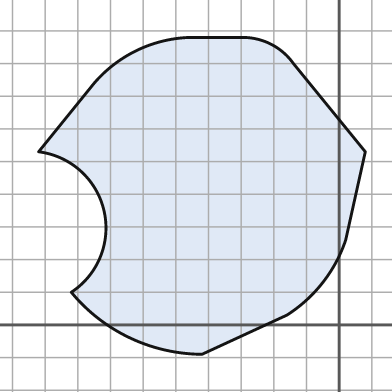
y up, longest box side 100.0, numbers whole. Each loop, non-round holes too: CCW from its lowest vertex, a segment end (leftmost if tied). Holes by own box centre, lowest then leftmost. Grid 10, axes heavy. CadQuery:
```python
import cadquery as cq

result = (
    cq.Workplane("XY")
    .moveTo(-42.0, -9.0)
    .lineTo(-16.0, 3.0)
    .threePointArc((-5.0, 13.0), (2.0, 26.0))
    .lineTo(8.0, 53.0)
    .lineTo(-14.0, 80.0)
    .threePointArc((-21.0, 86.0), (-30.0, 88.0))
    .lineTo(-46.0, 88.0)
    .threePointArc((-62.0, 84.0), (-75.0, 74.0))
    .lineTo(-92.0, 53.0)
    .threePointArc((-72.0, 35.0), (-82.0, 10.0))
    .threePointArc((-64.0, -4.0), (-42.0, -9.0))
    .close()
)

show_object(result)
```